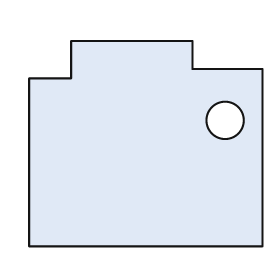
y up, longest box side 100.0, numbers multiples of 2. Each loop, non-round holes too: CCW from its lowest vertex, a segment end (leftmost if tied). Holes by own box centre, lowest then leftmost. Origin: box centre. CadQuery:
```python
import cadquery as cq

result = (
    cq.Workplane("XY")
    .moveTo(-50.0, -44.0)
    .lineTo(50.0, -44.0)
    .lineTo(50.0, 32.0)
    .lineTo(20.0, 32.0)
    .lineTo(20.0, 44.0)
    .lineTo(-32.0, 44.0)
    .lineTo(-32.0, 28.0)
    .lineTo(-50.0, 28.0)
    .close()
    .moveTo(34.0, 10.0)
    .circle(8.0)
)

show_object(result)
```